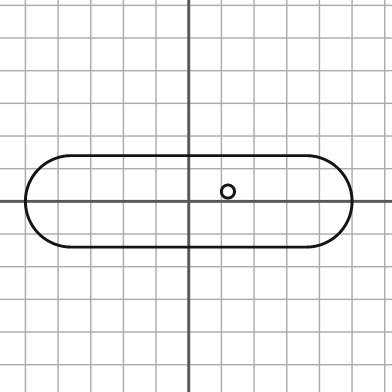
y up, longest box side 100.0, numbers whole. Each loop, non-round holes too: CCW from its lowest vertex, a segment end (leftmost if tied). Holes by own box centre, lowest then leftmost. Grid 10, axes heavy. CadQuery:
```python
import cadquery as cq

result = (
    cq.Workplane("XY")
    .moveTo(-36.0, -14.0)
    .lineTo(36.0, -14.0)
    .threePointArc((50.0, 0.0), (36.0, 14.0))
    .lineTo(-36.0, 14.0)
    .threePointArc((-50.0, 0.0), (-36.0, -14.0))
    .close()
    .moveTo(12.0, 3.0)
    .circle(2.0)
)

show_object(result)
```